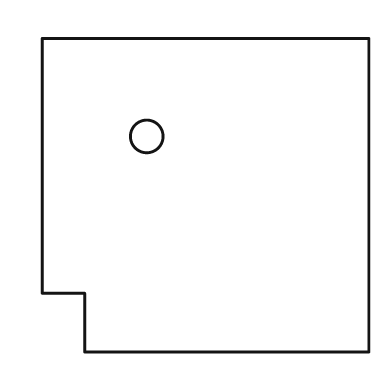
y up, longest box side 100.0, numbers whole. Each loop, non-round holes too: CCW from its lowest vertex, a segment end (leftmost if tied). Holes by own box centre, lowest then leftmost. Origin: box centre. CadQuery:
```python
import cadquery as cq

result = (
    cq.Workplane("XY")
    .moveTo(-37.0, -48.0)
    .lineTo(50.0, -48.0)
    .lineTo(50.0, 48.0)
    .lineTo(-50.0, 48.0)
    .lineTo(-50.0, -30.0)
    .lineTo(-37.0, -30.0)
    .close()
    .moveTo(-18.0, 18.0)
    .circle(5.0)
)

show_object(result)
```